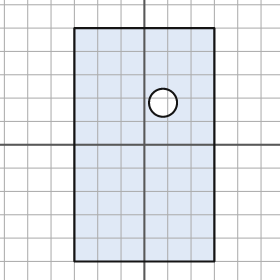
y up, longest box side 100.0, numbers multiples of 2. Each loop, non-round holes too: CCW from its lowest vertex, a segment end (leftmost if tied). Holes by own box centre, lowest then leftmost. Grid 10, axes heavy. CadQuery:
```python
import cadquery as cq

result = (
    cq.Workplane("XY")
    .moveTo(-30.0, -50.0)
    .lineTo(30.0, -50.0)
    .lineTo(30.0, 50.0)
    .lineTo(-30.0, 50.0)
    .close()
    .moveTo(8.0, 18.0)
    .circle(6.0)
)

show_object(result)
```